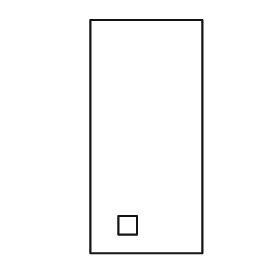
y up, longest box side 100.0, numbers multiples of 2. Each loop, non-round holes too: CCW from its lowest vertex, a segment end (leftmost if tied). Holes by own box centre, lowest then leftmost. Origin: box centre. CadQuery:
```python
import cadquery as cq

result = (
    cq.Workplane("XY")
    .moveTo(-24.0, -50.0)
    .lineTo(24.0, -50.0)
    .lineTo(24.0, 50.0)
    .lineTo(-24.0, 50.0)
    .close()
    .moveTo(-12.0, -42.0)
    .lineTo(-4.0, -42.0)
    .lineTo(-4.0, -34.0)
    .lineTo(-12.0, -34.0)
    .close()
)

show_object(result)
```